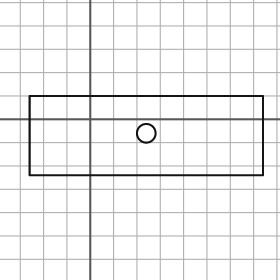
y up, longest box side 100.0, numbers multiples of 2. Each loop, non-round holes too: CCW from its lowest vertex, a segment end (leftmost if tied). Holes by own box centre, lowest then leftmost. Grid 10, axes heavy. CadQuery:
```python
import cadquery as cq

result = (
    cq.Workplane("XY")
    .moveTo(-26.0, -24.0)
    .lineTo(74.0, -24.0)
    .lineTo(74.0, 10.0)
    .lineTo(-26.0, 10.0)
    .close()
    .moveTo(24.0, -6.0)
    .circle(4.0)
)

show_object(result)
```